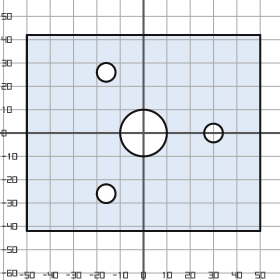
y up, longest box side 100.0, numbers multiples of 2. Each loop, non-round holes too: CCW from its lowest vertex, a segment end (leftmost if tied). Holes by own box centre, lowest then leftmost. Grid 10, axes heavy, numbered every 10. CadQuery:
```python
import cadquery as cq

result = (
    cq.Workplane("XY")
    .moveTo(-50.0, -42.0)
    .lineTo(50.0, -42.0)
    .lineTo(50.0, 42.0)
    .lineTo(-50.0, 42.0)
    .close()
    .moveTo(-16.0, -26.0)
    .circle(4.0)
    .moveTo(0.0, 0.0)
    .circle(10.0)
    .moveTo(30.0, 0.0)
    .circle(4.0)
    .moveTo(-16.0, 26.0)
    .circle(4.0)
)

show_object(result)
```